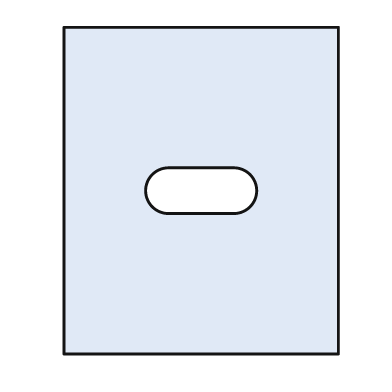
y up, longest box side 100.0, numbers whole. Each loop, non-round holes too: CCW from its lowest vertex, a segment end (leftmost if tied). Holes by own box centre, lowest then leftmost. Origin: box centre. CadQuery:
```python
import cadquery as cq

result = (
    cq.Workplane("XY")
    .moveTo(-42.0, -50.0)
    .lineTo(42.0, -50.0)
    .lineTo(42.0, 50.0)
    .lineTo(-42.0, 50.0)
    .close()
    .moveTo(-10.0, -7.0)
    .lineTo(10.0, -7.0)
    .threePointArc((17.0, 0.0), (10.0, 7.0))
    .lineTo(-10.0, 7.0)
    .threePointArc((-17.0, 0.0), (-10.0, -7.0))
    .close()
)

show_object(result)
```